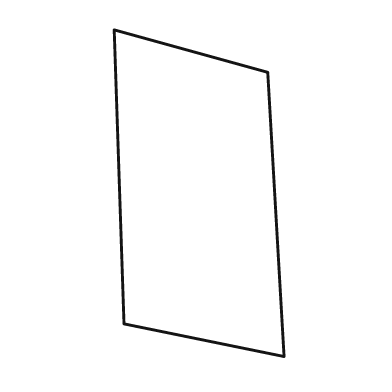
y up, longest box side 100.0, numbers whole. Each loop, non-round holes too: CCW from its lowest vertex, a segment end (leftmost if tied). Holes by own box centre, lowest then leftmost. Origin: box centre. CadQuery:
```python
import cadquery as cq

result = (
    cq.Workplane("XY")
    .moveTo(26.0, -50.0)
    .lineTo(21.0, 37.0)
    .lineTo(-26.0, 50.0)
    .lineTo(-23.0, -40.0)
    .close()
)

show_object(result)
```